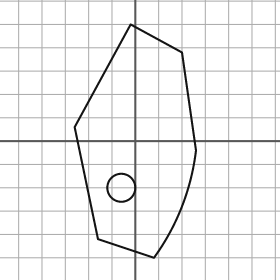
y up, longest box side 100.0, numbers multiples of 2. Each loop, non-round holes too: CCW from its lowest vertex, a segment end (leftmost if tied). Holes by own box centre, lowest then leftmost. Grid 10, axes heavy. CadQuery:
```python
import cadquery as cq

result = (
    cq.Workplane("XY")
    .moveTo(8.0, -50.0)
    .threePointArc((20.0, -28.0), (26.0, -4.0))
    .lineTo(20.0, 38.0)
    .lineTo(-2.0, 50.0)
    .lineTo(-26.0, 6.0)
    .lineTo(-16.0, -42.0)
    .close()
    .moveTo(-6.0, -20.0)
    .circle(6.0)
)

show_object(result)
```